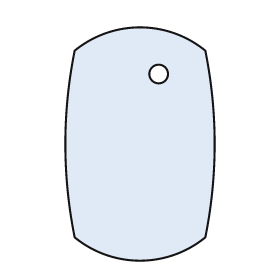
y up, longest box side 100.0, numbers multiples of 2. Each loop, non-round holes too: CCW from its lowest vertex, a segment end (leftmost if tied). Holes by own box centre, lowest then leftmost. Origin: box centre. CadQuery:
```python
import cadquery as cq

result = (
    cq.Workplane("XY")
    .moveTo(-28.0, -40.0)
    .threePointArc((0.0, -50.0), (28.0, -40.0))
    .threePointArc((32.0, 0.0), (28.0, 40.0))
    .threePointArc((0.0, 50.0), (-28.0, 40.0))
    .threePointArc((-32.0, 0.0), (-28.0, -40.0))
    .close()
    .moveTo(8.0, 30.0)
    .circle(4.0)
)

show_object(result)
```